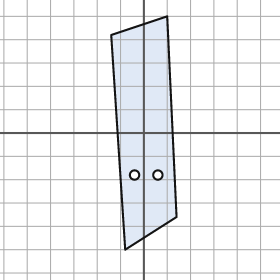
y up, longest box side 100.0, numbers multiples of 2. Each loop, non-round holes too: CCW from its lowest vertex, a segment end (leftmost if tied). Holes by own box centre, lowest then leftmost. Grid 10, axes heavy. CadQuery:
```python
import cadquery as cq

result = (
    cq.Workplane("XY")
    .moveTo(-8.0, -50.0)
    .lineTo(14.0, -36.0)
    .lineTo(10.0, 50.0)
    .lineTo(-14.0, 42.0)
    .close()
    .moveTo(-4.0, -18.0)
    .circle(2.0)
    .moveTo(6.0, -18.0)
    .circle(2.0)
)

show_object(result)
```